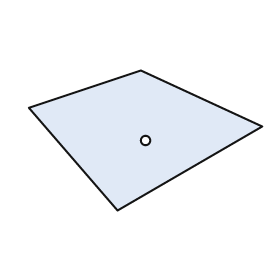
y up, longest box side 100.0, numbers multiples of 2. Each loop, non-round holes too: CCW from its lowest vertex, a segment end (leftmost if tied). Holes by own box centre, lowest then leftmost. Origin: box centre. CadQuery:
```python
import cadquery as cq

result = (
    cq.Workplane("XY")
    .moveTo(-12.0, -30.0)
    .lineTo(50.0, 6.0)
    .lineTo(-2.0, 30.0)
    .lineTo(-50.0, 14.0)
    .close()
    .moveTo(0.0, 0.0)
    .circle(2.0)
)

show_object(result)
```